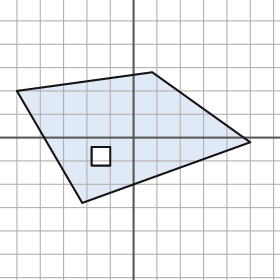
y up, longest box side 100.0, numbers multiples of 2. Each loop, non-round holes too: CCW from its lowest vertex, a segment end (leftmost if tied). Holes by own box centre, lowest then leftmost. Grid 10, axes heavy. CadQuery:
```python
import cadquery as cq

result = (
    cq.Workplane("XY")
    .moveTo(-22.0, -28.0)
    .lineTo(50.0, -2.0)
    .lineTo(8.0, 28.0)
    .lineTo(-50.0, 20.0)
    .close()
    .moveTo(-18.0, -12.0)
    .lineTo(-10.0, -12.0)
    .lineTo(-10.0, -4.0)
    .lineTo(-18.0, -4.0)
    .close()
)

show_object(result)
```